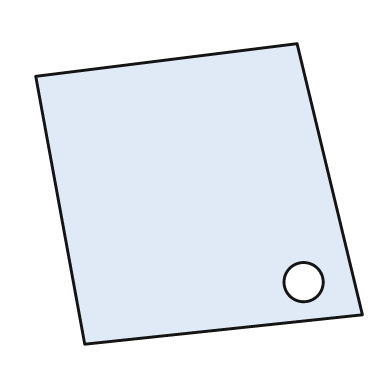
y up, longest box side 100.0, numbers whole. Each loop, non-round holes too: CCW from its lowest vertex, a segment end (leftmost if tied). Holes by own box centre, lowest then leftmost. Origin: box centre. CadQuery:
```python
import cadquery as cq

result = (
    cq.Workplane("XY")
    .moveTo(-35.0, -46.0)
    .lineTo(50.0, -37.0)
    .lineTo(30.0, 46.0)
    .lineTo(-50.0, 36.0)
    .close()
    .moveTo(32.0, -27.0)
    .circle(6.0)
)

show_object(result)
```